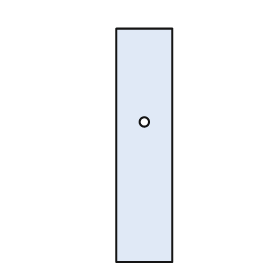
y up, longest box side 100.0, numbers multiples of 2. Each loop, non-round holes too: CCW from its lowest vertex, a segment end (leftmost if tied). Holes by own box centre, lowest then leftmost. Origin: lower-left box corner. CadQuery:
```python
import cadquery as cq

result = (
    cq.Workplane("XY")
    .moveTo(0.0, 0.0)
    .lineTo(24.0, 0.0)
    .lineTo(24.0, 100.0)
    .lineTo(0.0, 100.0)
    .close()
    .moveTo(12.0, 60.0)
    .circle(2.0)
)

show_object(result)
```